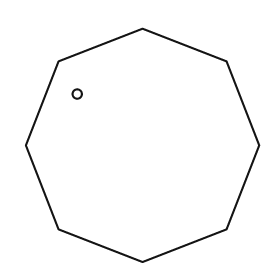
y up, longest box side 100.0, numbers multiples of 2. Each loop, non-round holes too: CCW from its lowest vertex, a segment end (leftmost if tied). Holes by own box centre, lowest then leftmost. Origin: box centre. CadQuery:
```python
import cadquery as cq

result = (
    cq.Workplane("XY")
    .moveTo(0.0, -50.0)
    .lineTo(36.0, -36.0)
    .lineTo(50.0, 0.0)
    .lineTo(36.0, 36.0)
    .lineTo(0.0, 50.0)
    .lineTo(-36.0, 36.0)
    .lineTo(-50.0, 0.0)
    .lineTo(-36.0, -36.0)
    .close()
    .moveTo(-28.0, 22.0)
    .circle(2.0)
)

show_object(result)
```